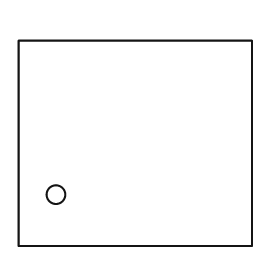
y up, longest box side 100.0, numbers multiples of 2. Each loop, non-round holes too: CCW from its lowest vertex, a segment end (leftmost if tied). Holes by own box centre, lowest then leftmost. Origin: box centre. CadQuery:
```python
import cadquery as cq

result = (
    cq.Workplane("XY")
    .moveTo(-50.0, -44.0)
    .lineTo(50.0, -44.0)
    .lineTo(50.0, 44.0)
    .lineTo(-50.0, 44.0)
    .close()
    .moveTo(-34.0, -22.0)
    .circle(4.0)
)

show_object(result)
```